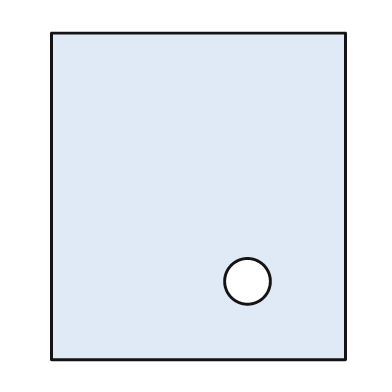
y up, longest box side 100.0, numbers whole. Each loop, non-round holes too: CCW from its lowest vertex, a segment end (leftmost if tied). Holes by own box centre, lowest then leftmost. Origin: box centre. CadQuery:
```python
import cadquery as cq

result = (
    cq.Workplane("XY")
    .moveTo(-45.0, -50.0)
    .lineTo(45.0, -50.0)
    .lineTo(45.0, 50.0)
    .lineTo(-45.0, 50.0)
    .close()
    .moveTo(15.0, -26.0)
    .circle(7.0)
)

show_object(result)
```